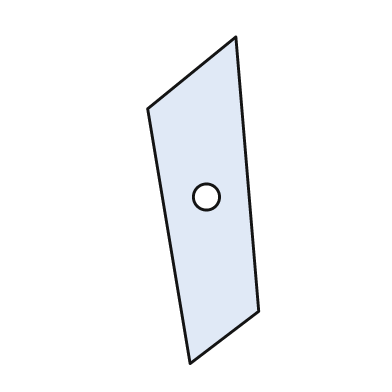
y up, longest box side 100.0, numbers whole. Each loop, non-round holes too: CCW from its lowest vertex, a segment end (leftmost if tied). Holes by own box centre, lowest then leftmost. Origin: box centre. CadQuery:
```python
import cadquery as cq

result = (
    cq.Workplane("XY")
    .moveTo(-4.0, -50.0)
    .lineTo(17.0, -34.0)
    .lineTo(10.0, 50.0)
    .lineTo(-17.0, 28.0)
    .close()
    .moveTo(1.0, 1.0)
    .circle(4.0)
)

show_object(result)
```